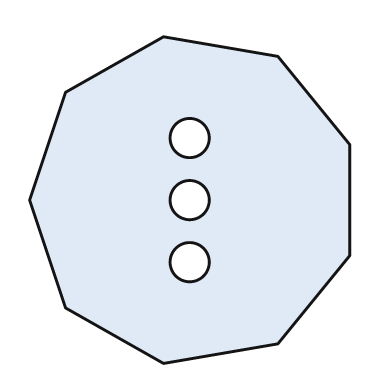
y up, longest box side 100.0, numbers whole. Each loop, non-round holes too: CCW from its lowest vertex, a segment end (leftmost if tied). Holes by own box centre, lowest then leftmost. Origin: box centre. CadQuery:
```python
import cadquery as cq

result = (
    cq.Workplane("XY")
    .moveTo(-8.0, -50.0)
    .lineTo(27.0, -44.0)
    .lineTo(49.0, -17.0)
    .lineTo(49.0, 17.0)
    .lineTo(27.0, 44.0)
    .lineTo(-8.0, 50.0)
    .lineTo(-38.0, 33.0)
    .lineTo(-49.0, 0.0)
    .lineTo(-38.0, -33.0)
    .close()
    .moveTo(0.0, -19.0)
    .circle(6.0)
    .moveTo(0.0, 0.0)
    .circle(6.0)
    .moveTo(0.0, 19.0)
    .circle(6.0)
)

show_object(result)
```